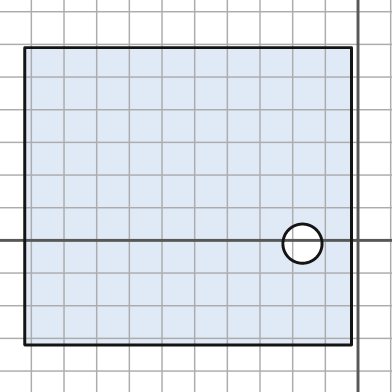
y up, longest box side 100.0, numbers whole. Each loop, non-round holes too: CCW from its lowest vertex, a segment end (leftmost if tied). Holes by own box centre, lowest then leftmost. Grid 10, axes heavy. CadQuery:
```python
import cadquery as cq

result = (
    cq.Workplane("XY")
    .moveTo(-102.0, -32.0)
    .lineTo(-2.0, -32.0)
    .lineTo(-2.0, 59.0)
    .lineTo(-102.0, 59.0)
    .close()
    .moveTo(-17.0, -1.0)
    .circle(6.0)
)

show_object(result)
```